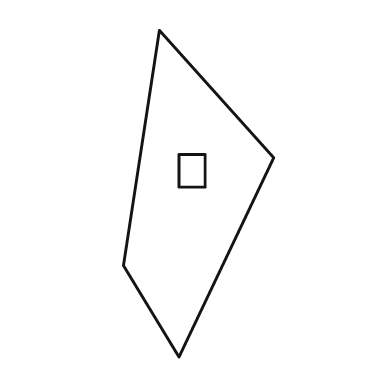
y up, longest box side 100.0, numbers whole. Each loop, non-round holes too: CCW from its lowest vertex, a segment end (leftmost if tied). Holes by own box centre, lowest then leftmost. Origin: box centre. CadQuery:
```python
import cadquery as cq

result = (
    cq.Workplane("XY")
    .moveTo(-6.0, -50.0)
    .lineTo(23.0, 11.0)
    .lineTo(-12.0, 50.0)
    .lineTo(-23.0, -22.0)
    .close()
    .moveTo(-6.0, 2.0)
    .lineTo(2.0, 2.0)
    .lineTo(2.0, 12.0)
    .lineTo(-6.0, 12.0)
    .close()
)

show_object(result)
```